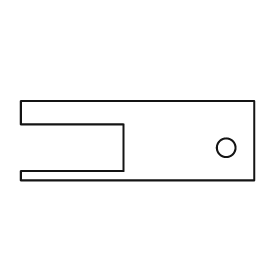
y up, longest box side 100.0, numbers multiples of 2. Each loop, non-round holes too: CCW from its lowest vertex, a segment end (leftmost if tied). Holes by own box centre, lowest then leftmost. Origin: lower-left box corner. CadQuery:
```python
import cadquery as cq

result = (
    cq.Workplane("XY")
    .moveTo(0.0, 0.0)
    .lineTo(100.0, 0.0)
    .lineTo(100.0, 34.0)
    .lineTo(0.0, 34.0)
    .lineTo(0.0, 24.0)
    .lineTo(44.0, 24.0)
    .lineTo(44.0, 4.0)
    .lineTo(0.0, 4.0)
    .close()
    .moveTo(88.0, 14.0)
    .circle(4.0)
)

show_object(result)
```